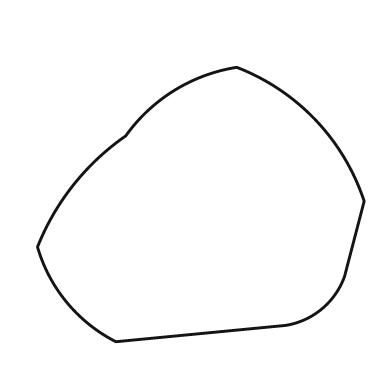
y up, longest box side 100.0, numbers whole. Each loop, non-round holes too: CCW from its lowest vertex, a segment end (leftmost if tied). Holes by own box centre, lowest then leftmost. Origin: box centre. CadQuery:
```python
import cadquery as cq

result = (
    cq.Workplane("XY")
    .moveTo(-26.0, -42.0)
    .lineTo(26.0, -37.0)
    .threePointArc((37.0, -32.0), (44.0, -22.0))
    .lineTo(50.0, 1.0)
    .threePointArc((35.0, 26.0), (11.0, 42.0))
    .threePointArc((-8.0, 35.0), (-23.0, 21.0))
    .threePointArc((-39.0, 6.0), (-50.0, -13.0))
    .threePointArc((-41.0, -30.0), (-26.0, -42.0))
    .close()
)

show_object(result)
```